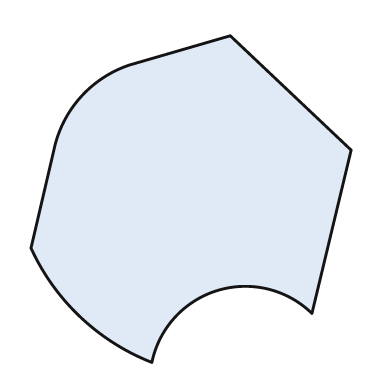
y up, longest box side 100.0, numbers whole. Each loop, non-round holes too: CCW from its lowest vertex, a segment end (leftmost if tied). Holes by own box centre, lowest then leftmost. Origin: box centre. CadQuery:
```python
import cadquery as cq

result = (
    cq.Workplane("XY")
    .moveTo(-12.0, -50.0)
    .threePointArc((8.0, -28.0), (37.0, -35.0))
    .lineTo(49.0, 15.0)
    .lineTo(12.0, 50.0)
    .lineTo(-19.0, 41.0)
    .threePointArc((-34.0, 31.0), (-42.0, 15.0))
    .lineTo(-49.0, -15.0)
    .threePointArc((-34.0, -36.0), (-12.0, -50.0))
    .close()
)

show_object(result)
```